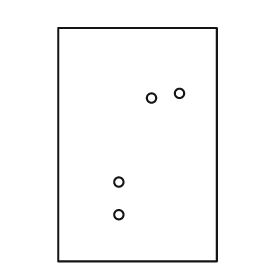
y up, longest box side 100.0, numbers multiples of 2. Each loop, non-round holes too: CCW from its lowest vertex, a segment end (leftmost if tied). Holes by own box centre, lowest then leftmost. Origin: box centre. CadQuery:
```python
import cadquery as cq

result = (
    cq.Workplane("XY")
    .moveTo(-34.0, -50.0)
    .lineTo(34.0, -50.0)
    .lineTo(34.0, 50.0)
    .lineTo(-34.0, 50.0)
    .close()
    .moveTo(-8.0, -30.0)
    .circle(2.0)
    .moveTo(-8.0, -16.0)
    .circle(2.0)
    .moveTo(6.0, 20.0)
    .circle(2.0)
    .moveTo(18.0, 22.0)
    .circle(2.0)
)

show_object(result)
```